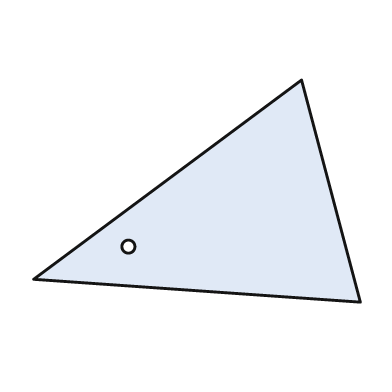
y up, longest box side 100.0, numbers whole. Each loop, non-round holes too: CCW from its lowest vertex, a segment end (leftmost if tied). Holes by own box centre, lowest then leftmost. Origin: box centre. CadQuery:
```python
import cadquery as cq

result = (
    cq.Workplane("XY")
    .moveTo(50.0, -34.0)
    .lineTo(32.0, 34.0)
    .lineTo(-50.0, -27.0)
    .close()
    .moveTo(-21.0, -17.0)
    .circle(2.0)
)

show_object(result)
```